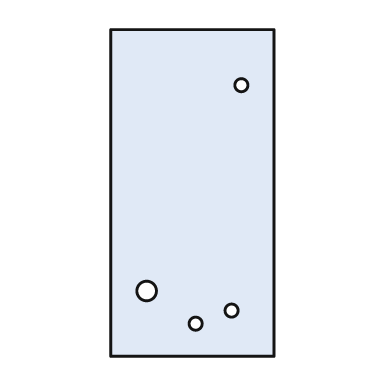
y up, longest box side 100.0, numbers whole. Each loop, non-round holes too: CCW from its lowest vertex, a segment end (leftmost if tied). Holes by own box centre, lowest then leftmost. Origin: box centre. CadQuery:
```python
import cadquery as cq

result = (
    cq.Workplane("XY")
    .moveTo(-25.0, -50.0)
    .lineTo(25.0, -50.0)
    .lineTo(25.0, 50.0)
    .lineTo(-25.0, 50.0)
    .close()
    .moveTo(1.0, -40.0)
    .circle(2.0)
    .moveTo(12.0, -36.0)
    .circle(2.0)
    .moveTo(-14.0, -30.0)
    .circle(3.0)
    .moveTo(15.0, 33.0)
    .circle(2.0)
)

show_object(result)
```